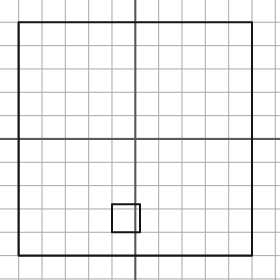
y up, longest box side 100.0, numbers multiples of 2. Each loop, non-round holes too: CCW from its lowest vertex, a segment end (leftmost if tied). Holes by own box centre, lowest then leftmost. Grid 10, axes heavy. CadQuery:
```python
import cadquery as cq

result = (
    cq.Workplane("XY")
    .moveTo(-50.0, -50.0)
    .lineTo(50.0, -50.0)
    .lineTo(50.0, 50.0)
    .lineTo(-50.0, 50.0)
    .close()
    .moveTo(-10.0, -40.0)
    .lineTo(2.0, -40.0)
    .lineTo(2.0, -28.0)
    .lineTo(-10.0, -28.0)
    .close()
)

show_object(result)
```